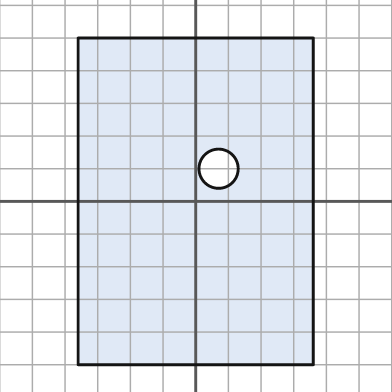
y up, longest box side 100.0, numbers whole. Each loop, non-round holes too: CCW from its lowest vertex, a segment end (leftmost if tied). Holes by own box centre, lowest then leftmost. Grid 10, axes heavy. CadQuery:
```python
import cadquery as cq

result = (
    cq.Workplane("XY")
    .moveTo(-36.0, -50.0)
    .lineTo(36.0, -50.0)
    .lineTo(36.0, 50.0)
    .lineTo(-36.0, 50.0)
    .close()
    .moveTo(7.0, 10.0)
    .circle(6.0)
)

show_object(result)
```